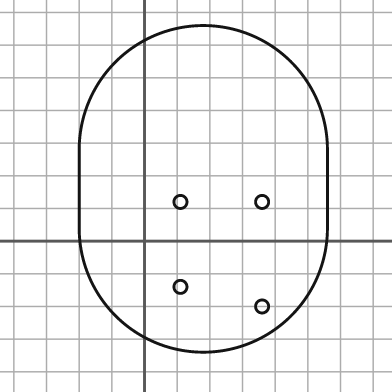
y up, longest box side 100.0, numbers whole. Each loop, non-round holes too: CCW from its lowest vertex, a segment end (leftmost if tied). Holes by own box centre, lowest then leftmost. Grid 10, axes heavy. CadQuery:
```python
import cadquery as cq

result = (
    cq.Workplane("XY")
    .moveTo(-20.0, 4.0)
    .threePointArc((18.0, -34.0), (56.0, 4.0))
    .lineTo(56.0, 28.0)
    .threePointArc((18.0, 66.0), (-20.0, 28.0))
    .close()
    .moveTo(36.0, -20.0)
    .circle(2.0)
    .moveTo(11.0, -14.0)
    .circle(2.0)
    .moveTo(11.0, 12.0)
    .circle(2.0)
    .moveTo(36.0, 12.0)
    .circle(2.0)
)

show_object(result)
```